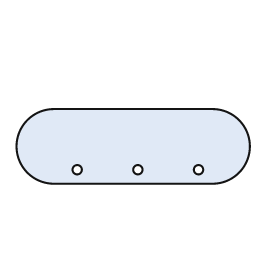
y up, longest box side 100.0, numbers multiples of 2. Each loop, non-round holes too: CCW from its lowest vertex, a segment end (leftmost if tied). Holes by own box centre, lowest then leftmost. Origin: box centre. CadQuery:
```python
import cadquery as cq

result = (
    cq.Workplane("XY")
    .moveTo(-34.0, -16.0)
    .lineTo(34.0, -16.0)
    .threePointArc((50.0, 0.0), (34.0, 16.0))
    .lineTo(-34.0, 16.0)
    .threePointArc((-50.0, 0.0), (-34.0, -16.0))
    .close()
    .moveTo(-24.0, -10.0)
    .circle(2.0)
    .moveTo(2.0, -10.0)
    .circle(2.0)
    .moveTo(28.0, -10.0)
    .circle(2.0)
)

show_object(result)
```